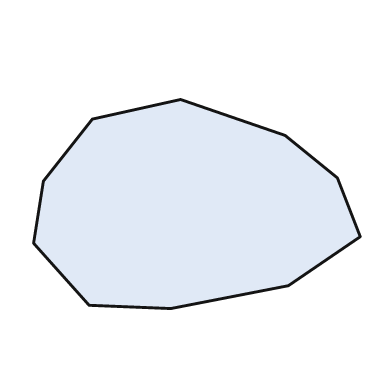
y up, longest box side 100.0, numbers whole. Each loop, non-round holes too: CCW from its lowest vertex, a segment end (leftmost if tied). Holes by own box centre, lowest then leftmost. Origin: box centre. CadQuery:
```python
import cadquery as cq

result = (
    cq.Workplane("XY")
    .moveTo(-8.0, -32.0)
    .lineTo(28.0, -25.0)
    .lineTo(50.0, -10.0)
    .lineTo(43.0, 8.0)
    .lineTo(27.0, 21.0)
    .lineTo(-5.0, 32.0)
    .lineTo(-32.0, 26.0)
    .lineTo(-47.0, 7.0)
    .lineTo(-50.0, -12.0)
    .lineTo(-33.0, -31.0)
    .close()
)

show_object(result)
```